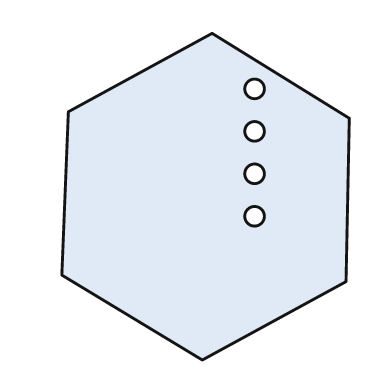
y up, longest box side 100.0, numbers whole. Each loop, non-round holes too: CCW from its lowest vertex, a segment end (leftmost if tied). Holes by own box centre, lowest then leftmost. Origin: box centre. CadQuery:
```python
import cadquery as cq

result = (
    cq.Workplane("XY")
    .moveTo(-1.0, -50.0)
    .lineTo(43.0, -26.0)
    .lineTo(44.0, 24.0)
    .lineTo(2.0, 50.0)
    .lineTo(-42.0, 26.0)
    .lineTo(-44.0, -24.0)
    .close()
    .moveTo(15.0, -6.0)
    .circle(3.0)
    .moveTo(15.0, 7.0)
    .circle(3.0)
    .moveTo(15.0, 20.0)
    .circle(3.0)
    .moveTo(15.0, 33.0)
    .circle(3.0)
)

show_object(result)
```